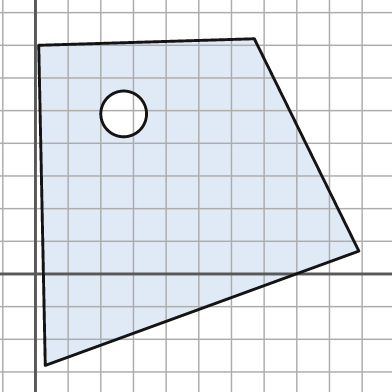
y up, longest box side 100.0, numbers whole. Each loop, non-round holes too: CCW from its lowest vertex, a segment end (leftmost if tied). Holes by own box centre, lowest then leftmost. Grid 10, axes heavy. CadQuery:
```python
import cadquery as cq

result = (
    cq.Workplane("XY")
    .moveTo(3.0, -28.0)
    .lineTo(99.0, 7.0)
    .lineTo(67.0, 72.0)
    .lineTo(1.0, 70.0)
    .close()
    .moveTo(27.0, 49.0)
    .circle(7.0)
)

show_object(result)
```